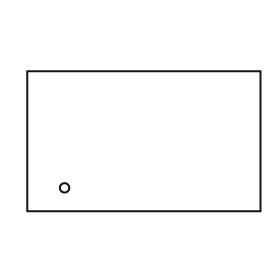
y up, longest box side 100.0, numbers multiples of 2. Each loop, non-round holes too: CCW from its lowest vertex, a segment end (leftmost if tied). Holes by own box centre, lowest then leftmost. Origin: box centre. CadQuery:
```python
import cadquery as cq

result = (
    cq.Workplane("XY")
    .moveTo(-50.0, -30.0)
    .lineTo(50.0, -30.0)
    .lineTo(50.0, 30.0)
    .lineTo(-50.0, 30.0)
    .close()
    .moveTo(-34.0, -20.0)
    .circle(2.0)
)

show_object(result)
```